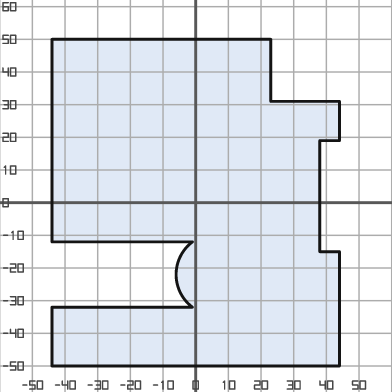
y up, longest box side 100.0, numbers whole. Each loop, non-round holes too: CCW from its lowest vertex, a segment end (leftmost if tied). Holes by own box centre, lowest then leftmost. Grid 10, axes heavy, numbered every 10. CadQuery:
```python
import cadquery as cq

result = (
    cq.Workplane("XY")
    .moveTo(-44.0, -50.0)
    .lineTo(44.0, -50.0)
    .lineTo(44.0, -15.0)
    .lineTo(38.0, -15.0)
    .lineTo(38.0, 19.0)
    .lineTo(44.0, 19.0)
    .lineTo(44.0, 31.0)
    .lineTo(23.0, 31.0)
    .lineTo(23.0, 50.0)
    .lineTo(-44.0, 50.0)
    .lineTo(-44.0, -12.0)
    .lineTo(-1.0, -12.0)
    .threePointArc((-6.0, -22.0), (-1.0, -32.0))
    .lineTo(-44.0, -32.0)
    .close()
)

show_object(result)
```